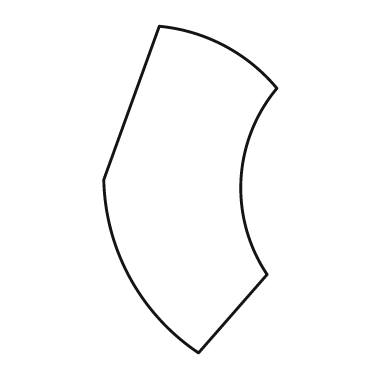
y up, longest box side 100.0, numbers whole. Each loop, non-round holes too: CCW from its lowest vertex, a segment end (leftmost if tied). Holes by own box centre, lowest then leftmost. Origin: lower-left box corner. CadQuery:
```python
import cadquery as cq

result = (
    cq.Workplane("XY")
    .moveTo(29.0, 0.0)
    .lineTo(50.0, 24.0)
    .threePointArc((42.0, 53.0), (53.0, 81.0))
    .threePointArc((37.0, 94.0), (17.0, 100.0))
    .lineTo(0.0, 53.0)
    .threePointArc((8.0, 23.0), (29.0, 0.0))
    .close()
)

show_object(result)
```